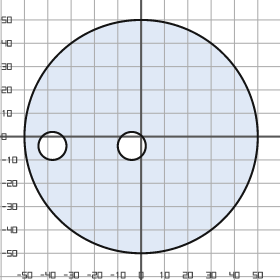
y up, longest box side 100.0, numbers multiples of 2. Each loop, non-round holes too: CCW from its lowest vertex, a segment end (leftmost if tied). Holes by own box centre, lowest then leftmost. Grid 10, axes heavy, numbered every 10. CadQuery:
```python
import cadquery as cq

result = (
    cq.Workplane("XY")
    .moveTo(0.0, 0.0)
    .circle(50.0)
    .moveTo(-38.0, -4.0)
    .circle(6.0)
    .moveTo(-4.0, -4.0)
    .circle(6.0)
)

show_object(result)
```